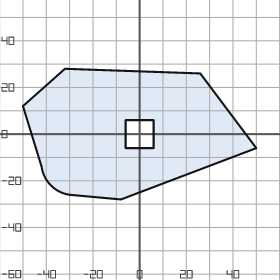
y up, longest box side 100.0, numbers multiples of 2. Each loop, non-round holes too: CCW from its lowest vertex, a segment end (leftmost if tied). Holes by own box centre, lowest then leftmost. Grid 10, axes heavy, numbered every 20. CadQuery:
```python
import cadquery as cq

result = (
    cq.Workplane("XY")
    .moveTo(-8.0, -28.0)
    .lineTo(50.0, -6.0)
    .lineTo(26.0, 26.0)
    .lineTo(-32.0, 28.0)
    .lineTo(-50.0, 12.0)
    .lineTo(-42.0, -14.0)
    .threePointArc((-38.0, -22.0), (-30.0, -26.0))
    .close()
    .moveTo(-6.0, -6.0)
    .lineTo(6.0, -6.0)
    .lineTo(6.0, 6.0)
    .lineTo(-6.0, 6.0)
    .close()
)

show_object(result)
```